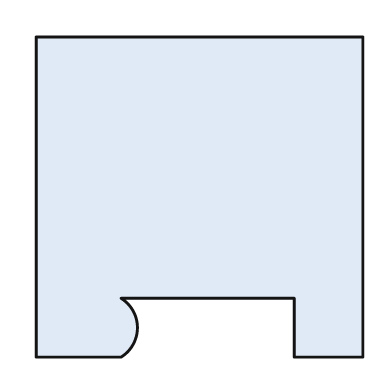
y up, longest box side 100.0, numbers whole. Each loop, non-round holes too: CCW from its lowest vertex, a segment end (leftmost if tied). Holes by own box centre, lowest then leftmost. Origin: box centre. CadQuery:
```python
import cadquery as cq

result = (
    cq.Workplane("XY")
    .moveTo(-50.0, -49.0)
    .lineTo(-24.0, -49.0)
    .threePointArc((-19.0, -40.0), (-24.0, -31.0))
    .lineTo(29.0, -31.0)
    .lineTo(29.0, -49.0)
    .lineTo(50.0, -49.0)
    .lineTo(50.0, 49.0)
    .lineTo(-50.0, 49.0)
    .close()
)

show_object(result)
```